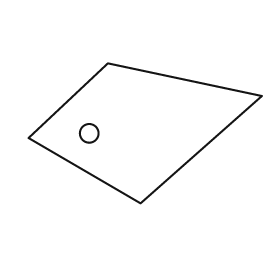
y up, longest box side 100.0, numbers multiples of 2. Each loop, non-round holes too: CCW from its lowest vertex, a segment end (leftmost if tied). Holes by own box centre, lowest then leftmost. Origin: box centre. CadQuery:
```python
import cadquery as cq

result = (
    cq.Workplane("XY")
    .moveTo(-2.0, -30.0)
    .lineTo(50.0, 16.0)
    .lineTo(-16.0, 30.0)
    .lineTo(-50.0, -2.0)
    .close()
    .moveTo(-24.0, 0.0)
    .circle(4.0)
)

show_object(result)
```